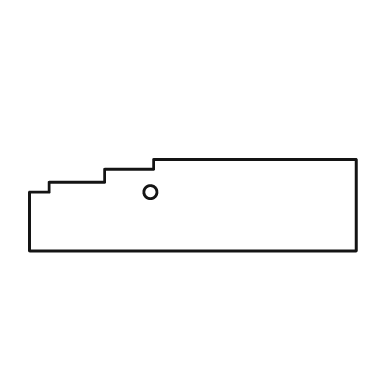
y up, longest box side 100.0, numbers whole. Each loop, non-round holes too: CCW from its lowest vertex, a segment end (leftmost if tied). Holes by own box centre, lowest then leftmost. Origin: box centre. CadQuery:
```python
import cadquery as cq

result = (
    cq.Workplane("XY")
    .moveTo(-50.0, -14.0)
    .lineTo(50.0, -14.0)
    .lineTo(50.0, 14.0)
    .lineTo(-12.0, 14.0)
    .lineTo(-12.0, 11.0)
    .lineTo(-27.0, 11.0)
    .lineTo(-27.0, 7.0)
    .lineTo(-44.0, 7.0)
    .lineTo(-44.0, 4.0)
    .lineTo(-50.0, 4.0)
    .close()
    .moveTo(-13.0, 4.0)
    .circle(2.0)
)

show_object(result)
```